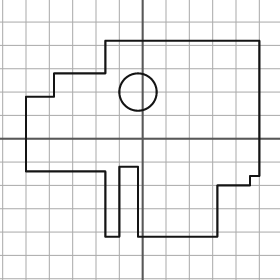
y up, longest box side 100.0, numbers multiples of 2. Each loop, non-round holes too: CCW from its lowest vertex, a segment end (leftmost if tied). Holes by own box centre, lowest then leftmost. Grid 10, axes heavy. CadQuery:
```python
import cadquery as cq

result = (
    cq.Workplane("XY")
    .moveTo(-16.0, -42.0)
    .lineTo(-10.0, -42.0)
    .lineTo(-10.0, -12.0)
    .lineTo(-2.0, -12.0)
    .lineTo(-2.0, -42.0)
    .lineTo(32.0, -42.0)
    .lineTo(32.0, -20.0)
    .lineTo(46.0, -20.0)
    .lineTo(46.0, -16.0)
    .lineTo(50.0, -16.0)
    .lineTo(50.0, 42.0)
    .lineTo(-16.0, 42.0)
    .lineTo(-16.0, 28.0)
    .lineTo(-38.0, 28.0)
    .lineTo(-38.0, 18.0)
    .lineTo(-50.0, 18.0)
    .lineTo(-50.0, -14.0)
    .lineTo(-16.0, -14.0)
    .close()
    .moveTo(-2.0, 20.0)
    .circle(8.0)
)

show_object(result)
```